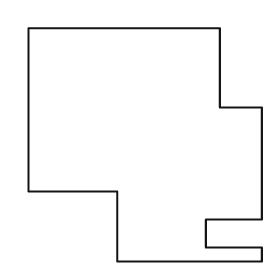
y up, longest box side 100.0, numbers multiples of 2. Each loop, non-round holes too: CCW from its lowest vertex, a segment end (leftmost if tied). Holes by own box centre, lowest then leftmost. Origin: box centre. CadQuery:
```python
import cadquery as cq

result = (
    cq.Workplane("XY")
    .moveTo(-12.0, -50.0)
    .lineTo(50.0, -50.0)
    .lineTo(50.0, -44.0)
    .lineTo(26.0, -44.0)
    .lineTo(26.0, -32.0)
    .lineTo(50.0, -32.0)
    .lineTo(50.0, 16.0)
    .lineTo(32.0, 16.0)
    .lineTo(32.0, 50.0)
    .lineTo(-50.0, 50.0)
    .lineTo(-50.0, -20.0)
    .lineTo(-12.0, -20.0)
    .close()
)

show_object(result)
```